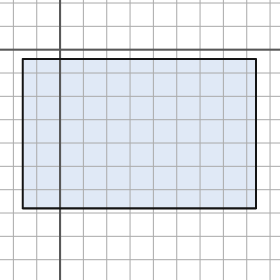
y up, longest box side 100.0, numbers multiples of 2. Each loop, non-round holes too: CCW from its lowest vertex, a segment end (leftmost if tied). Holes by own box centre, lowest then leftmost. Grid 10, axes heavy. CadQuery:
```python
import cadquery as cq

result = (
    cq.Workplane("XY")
    .moveTo(-16.0, -68.0)
    .lineTo(84.0, -68.0)
    .lineTo(84.0, -4.0)
    .lineTo(-16.0, -4.0)
    .close()
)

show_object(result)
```